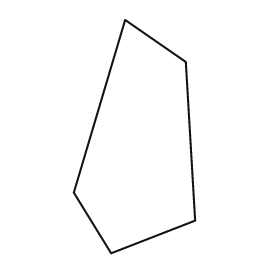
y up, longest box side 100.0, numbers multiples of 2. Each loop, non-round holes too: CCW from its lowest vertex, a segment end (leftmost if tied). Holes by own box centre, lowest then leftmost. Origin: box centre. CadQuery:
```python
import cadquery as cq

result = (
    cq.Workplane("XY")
    .moveTo(-10.0, -50.0)
    .lineTo(26.0, -36.0)
    .lineTo(22.0, 32.0)
    .lineTo(-4.0, 50.0)
    .lineTo(-26.0, -24.0)
    .close()
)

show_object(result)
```